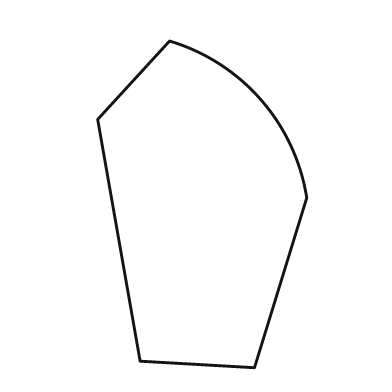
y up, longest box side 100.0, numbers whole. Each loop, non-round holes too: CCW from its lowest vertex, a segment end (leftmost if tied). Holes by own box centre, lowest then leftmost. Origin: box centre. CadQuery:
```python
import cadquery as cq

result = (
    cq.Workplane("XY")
    .moveTo(16.0, -50.0)
    .lineTo(32.0, 2.0)
    .threePointArc((18.0, 32.0), (-10.0, 50.0))
    .lineTo(-32.0, 26.0)
    .lineTo(-19.0, -48.0)
    .close()
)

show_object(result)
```